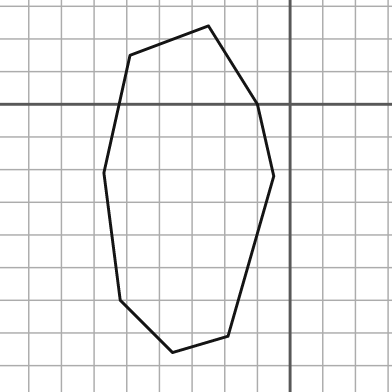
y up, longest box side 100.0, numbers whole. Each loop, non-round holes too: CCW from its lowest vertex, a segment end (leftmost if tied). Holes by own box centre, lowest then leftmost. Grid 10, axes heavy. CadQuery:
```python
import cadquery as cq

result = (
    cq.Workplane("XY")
    .moveTo(-36.0, -76.0)
    .lineTo(-19.0, -71.0)
    .lineTo(-5.0, -22.0)
    .lineTo(-10.0, 0.0)
    .lineTo(-25.0, 24.0)
    .lineTo(-49.0, 15.0)
    .lineTo(-57.0, -21.0)
    .lineTo(-52.0, -60.0)
    .close()
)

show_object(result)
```